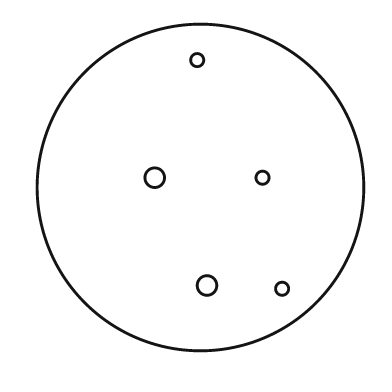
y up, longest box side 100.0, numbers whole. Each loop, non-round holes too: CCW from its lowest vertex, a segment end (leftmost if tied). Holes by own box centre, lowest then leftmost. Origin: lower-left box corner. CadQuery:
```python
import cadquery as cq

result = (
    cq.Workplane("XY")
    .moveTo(50.0, 50.0)
    .circle(50.0)
    .moveTo(75.0, 19.0)
    .circle(2.0)
    .moveTo(52.0, 20.0)
    .circle(3.0)
    .moveTo(36.0, 53.0)
    .circle(3.0)
    .moveTo(69.0, 53.0)
    .circle(2.0)
    .moveTo(49.0, 89.0)
    .circle(2.0)
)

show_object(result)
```